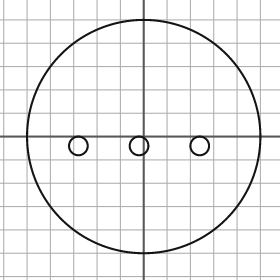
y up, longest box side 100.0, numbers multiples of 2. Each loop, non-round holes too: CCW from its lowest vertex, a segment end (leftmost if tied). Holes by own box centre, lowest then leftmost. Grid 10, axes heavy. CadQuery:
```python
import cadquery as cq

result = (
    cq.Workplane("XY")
    .moveTo(0.0, 0.0)
    .circle(50.0)
    .moveTo(-28.0, -4.0)
    .circle(4.0)
    .moveTo(-2.0, -4.0)
    .circle(4.0)
    .moveTo(24.0, -4.0)
    .circle(4.0)
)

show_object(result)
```